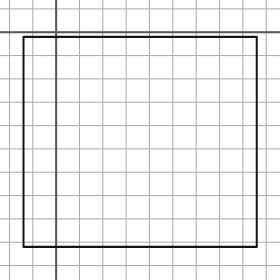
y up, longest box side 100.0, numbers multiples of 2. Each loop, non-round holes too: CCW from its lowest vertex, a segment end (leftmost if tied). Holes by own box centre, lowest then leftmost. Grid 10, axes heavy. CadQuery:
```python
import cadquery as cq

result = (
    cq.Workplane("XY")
    .moveTo(-14.0, -92.0)
    .lineTo(86.0, -92.0)
    .lineTo(86.0, -2.0)
    .lineTo(-14.0, -2.0)
    .close()
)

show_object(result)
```